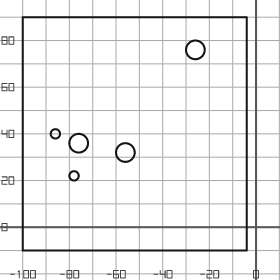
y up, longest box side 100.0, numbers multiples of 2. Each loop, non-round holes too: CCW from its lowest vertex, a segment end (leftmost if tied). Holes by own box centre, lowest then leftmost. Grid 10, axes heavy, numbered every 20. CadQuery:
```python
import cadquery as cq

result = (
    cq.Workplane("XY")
    .moveTo(-100.0, -10.0)
    .lineTo(-4.0, -10.0)
    .lineTo(-4.0, 90.0)
    .lineTo(-100.0, 90.0)
    .close()
    .moveTo(-78.0, 22.0)
    .circle(2.0)
    .moveTo(-56.0, 32.0)
    .circle(4.0)
    .moveTo(-76.0, 36.0)
    .circle(4.0)
    .moveTo(-86.0, 40.0)
    .circle(2.0)
    .moveTo(-26.0, 76.0)
    .circle(4.0)
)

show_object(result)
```